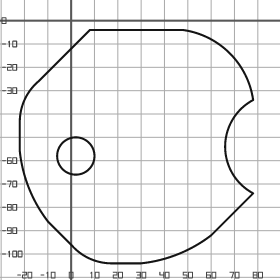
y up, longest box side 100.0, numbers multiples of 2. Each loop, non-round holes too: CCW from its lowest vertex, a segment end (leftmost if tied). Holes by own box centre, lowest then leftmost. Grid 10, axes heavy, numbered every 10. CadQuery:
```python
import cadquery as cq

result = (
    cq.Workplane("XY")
    .moveTo(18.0, -104.0)
    .lineTo(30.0, -104.0)
    .threePointArc((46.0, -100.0), (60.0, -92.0))
    .lineTo(78.0, -74.0)
    .threePointArc((66.0, -54.0), (78.0, -34.0))
    .threePointArc((68.0, -14.0), (48.0, -4.0))
    .lineTo(8.0, -4.0)
    .lineTo(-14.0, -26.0)
    .threePointArc((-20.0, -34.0), (-22.0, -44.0))
    .lineTo(-22.0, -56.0)
    .threePointArc((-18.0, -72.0), (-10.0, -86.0))
    .lineTo(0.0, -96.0)
    .threePointArc((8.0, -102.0), (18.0, -104.0))
    .close()
    .moveTo(2.0, -58.0)
    .circle(8.0)
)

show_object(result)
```